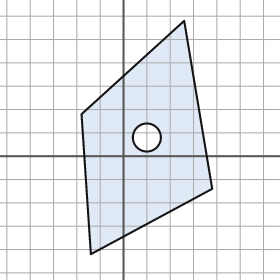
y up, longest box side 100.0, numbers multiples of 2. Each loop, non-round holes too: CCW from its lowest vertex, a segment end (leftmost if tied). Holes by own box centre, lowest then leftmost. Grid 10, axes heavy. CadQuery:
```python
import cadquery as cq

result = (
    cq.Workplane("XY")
    .moveTo(-14.0, -42.0)
    .lineTo(38.0, -14.0)
    .lineTo(26.0, 58.0)
    .lineTo(-18.0, 18.0)
    .close()
    .moveTo(10.0, 8.0)
    .circle(6.0)
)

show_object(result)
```